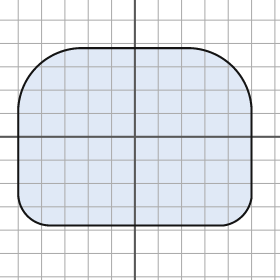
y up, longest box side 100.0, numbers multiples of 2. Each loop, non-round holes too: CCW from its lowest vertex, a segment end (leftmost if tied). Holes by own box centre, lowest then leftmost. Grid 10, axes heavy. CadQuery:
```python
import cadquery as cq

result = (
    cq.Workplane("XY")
    .moveTo(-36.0, -38.0)
    .lineTo(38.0, -38.0)
    .threePointArc((46.0, -34.0), (50.0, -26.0))
    .lineTo(50.0, 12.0)
    .threePointArc((42.0, 30.0), (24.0, 38.0))
    .lineTo(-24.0, 38.0)
    .threePointArc((-42.0, 30.0), (-50.0, 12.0))
    .lineTo(-50.0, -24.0)
    .threePointArc((-46.0, -34.0), (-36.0, -38.0))
    .close()
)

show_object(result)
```